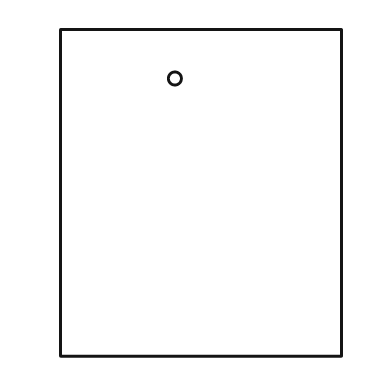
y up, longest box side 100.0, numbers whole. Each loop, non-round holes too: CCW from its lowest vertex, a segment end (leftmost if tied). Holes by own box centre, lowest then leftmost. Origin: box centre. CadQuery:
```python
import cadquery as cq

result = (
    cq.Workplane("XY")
    .moveTo(-43.0, -50.0)
    .lineTo(43.0, -50.0)
    .lineTo(43.0, 50.0)
    .lineTo(-43.0, 50.0)
    .close()
    .moveTo(-8.0, 35.0)
    .circle(2.0)
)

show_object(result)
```